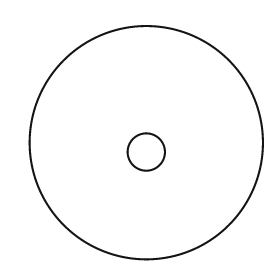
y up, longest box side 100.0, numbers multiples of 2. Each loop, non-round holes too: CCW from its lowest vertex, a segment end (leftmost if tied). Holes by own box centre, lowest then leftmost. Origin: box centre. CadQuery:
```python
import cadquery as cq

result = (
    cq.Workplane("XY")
    .moveTo(0.0, 0.0)
    .circle(50.0)
    .moveTo(0.0, -4.0)
    .circle(8.0)
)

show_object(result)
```